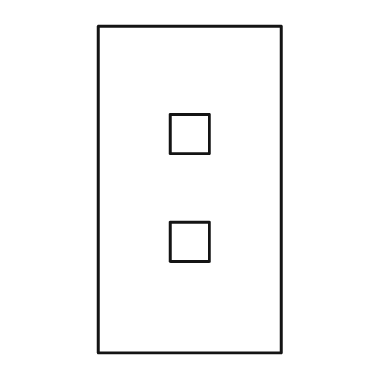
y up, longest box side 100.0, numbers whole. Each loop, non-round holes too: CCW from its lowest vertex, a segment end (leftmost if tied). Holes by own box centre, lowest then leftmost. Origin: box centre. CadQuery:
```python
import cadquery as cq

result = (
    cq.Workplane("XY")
    .moveTo(-28.0, -50.0)
    .lineTo(28.0, -50.0)
    .lineTo(28.0, 50.0)
    .lineTo(-28.0, 50.0)
    .close()
    .moveTo(-6.0, -22.0)
    .lineTo(6.0, -22.0)
    .lineTo(6.0, -10.0)
    .lineTo(-6.0, -10.0)
    .close()
    .moveTo(-6.0, 11.0)
    .lineTo(6.0, 11.0)
    .lineTo(6.0, 23.0)
    .lineTo(-6.0, 23.0)
    .close()
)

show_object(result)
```